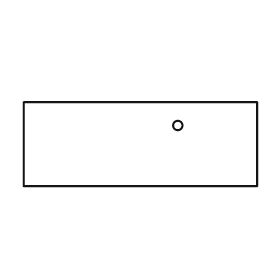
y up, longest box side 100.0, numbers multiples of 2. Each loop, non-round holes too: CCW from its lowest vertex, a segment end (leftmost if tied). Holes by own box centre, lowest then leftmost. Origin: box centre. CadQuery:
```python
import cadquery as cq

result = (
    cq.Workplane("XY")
    .moveTo(-50.0, -18.0)
    .lineTo(50.0, -18.0)
    .lineTo(50.0, 18.0)
    .lineTo(-50.0, 18.0)
    .close()
    .moveTo(16.0, 8.0)
    .circle(2.0)
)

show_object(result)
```